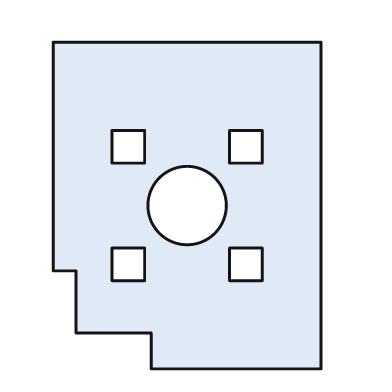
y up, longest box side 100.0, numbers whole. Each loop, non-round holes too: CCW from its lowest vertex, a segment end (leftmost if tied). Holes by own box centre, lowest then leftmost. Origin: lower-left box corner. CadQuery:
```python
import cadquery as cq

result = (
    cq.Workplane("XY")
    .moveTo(30.0, 0.0)
    .lineTo(82.0, 0.0)
    .lineTo(82.0, 100.0)
    .lineTo(0.0, 100.0)
    .lineTo(0.0, 30.0)
    .lineTo(7.0, 30.0)
    .lineTo(7.0, 11.0)
    .lineTo(30.0, 11.0)
    .close()
    .moveTo(18.0, 27.0)
    .lineTo(28.0, 27.0)
    .lineTo(28.0, 37.0)
    .lineTo(18.0, 37.0)
    .close()
    .moveTo(54.0, 27.0)
    .lineTo(64.0, 27.0)
    .lineTo(64.0, 37.0)
    .lineTo(54.0, 37.0)
    .close()
    .moveTo(41.0, 50.0)
    .circle(12.0)
    .moveTo(18.0, 63.0)
    .lineTo(28.0, 63.0)
    .lineTo(28.0, 73.0)
    .lineTo(18.0, 73.0)
    .close()
    .moveTo(54.0, 63.0)
    .lineTo(64.0, 63.0)
    .lineTo(64.0, 73.0)
    .lineTo(54.0, 73.0)
    .close()
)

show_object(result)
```